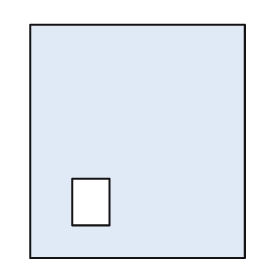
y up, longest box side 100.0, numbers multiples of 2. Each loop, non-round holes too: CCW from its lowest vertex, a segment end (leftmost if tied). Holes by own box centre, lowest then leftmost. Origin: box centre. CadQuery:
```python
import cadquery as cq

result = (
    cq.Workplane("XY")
    .moveTo(-46.0, -50.0)
    .lineTo(46.0, -50.0)
    .lineTo(46.0, 50.0)
    .lineTo(-46.0, 50.0)
    .close()
    .moveTo(-28.0, -36.0)
    .lineTo(-12.0, -36.0)
    .lineTo(-12.0, -16.0)
    .lineTo(-28.0, -16.0)
    .close()
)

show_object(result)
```